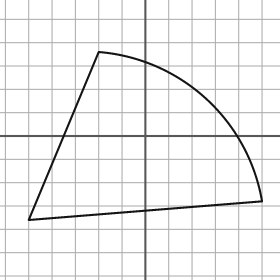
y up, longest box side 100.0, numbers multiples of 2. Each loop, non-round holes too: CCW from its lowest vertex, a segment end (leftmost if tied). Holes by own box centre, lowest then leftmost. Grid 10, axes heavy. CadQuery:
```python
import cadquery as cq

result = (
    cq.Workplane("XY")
    .moveTo(-50.0, -36.0)
    .lineTo(50.0, -28.0)
    .threePointArc((26.0, 16.0), (-20.0, 36.0))
    .close()
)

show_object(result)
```